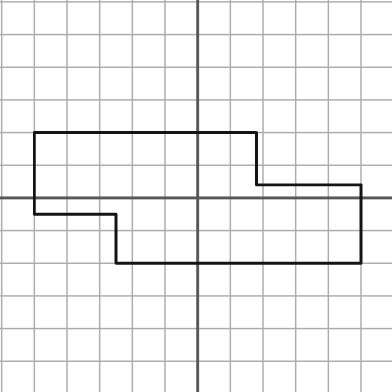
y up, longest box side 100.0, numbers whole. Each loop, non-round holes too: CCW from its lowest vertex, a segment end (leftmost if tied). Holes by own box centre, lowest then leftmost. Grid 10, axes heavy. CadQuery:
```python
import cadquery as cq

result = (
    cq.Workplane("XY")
    .moveTo(-25.0, -20.0)
    .lineTo(50.0, -20.0)
    .lineTo(50.0, 4.0)
    .lineTo(18.0, 4.0)
    .lineTo(18.0, 20.0)
    .lineTo(-50.0, 20.0)
    .lineTo(-50.0, -5.0)
    .lineTo(-25.0, -5.0)
    .close()
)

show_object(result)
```